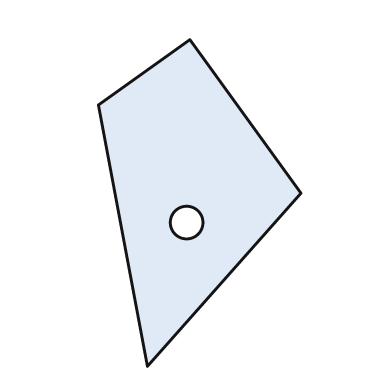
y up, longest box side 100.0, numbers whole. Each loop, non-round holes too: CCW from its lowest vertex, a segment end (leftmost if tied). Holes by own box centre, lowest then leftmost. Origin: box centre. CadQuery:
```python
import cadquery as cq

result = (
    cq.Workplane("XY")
    .moveTo(-16.0, -50.0)
    .lineTo(31.0, 3.0)
    .lineTo(-3.0, 50.0)
    .lineTo(-31.0, 30.0)
    .close()
    .moveTo(-4.0, -6.0)
    .circle(5.0)
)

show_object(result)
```